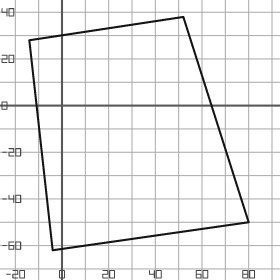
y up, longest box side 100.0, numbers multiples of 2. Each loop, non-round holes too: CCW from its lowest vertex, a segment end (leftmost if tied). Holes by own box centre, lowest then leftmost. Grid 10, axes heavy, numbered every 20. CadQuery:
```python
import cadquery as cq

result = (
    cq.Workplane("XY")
    .moveTo(-4.0, -62.0)
    .lineTo(80.0, -50.0)
    .lineTo(52.0, 38.0)
    .lineTo(-14.0, 28.0)
    .close()
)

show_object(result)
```